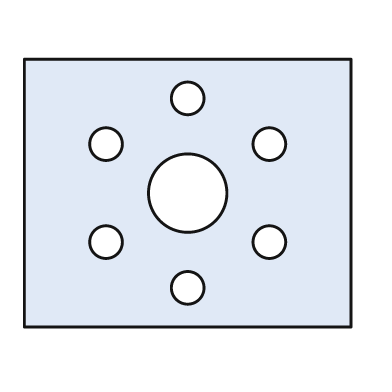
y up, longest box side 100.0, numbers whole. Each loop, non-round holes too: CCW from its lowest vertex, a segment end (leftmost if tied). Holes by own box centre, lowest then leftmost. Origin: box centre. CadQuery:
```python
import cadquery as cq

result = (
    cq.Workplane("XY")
    .moveTo(-50.0, -41.0)
    .lineTo(50.0, -41.0)
    .lineTo(50.0, 41.0)
    .lineTo(-50.0, 41.0)
    .close()
    .moveTo(0.0, -29.0)
    .circle(5.0)
    .moveTo(-25.0, -15.0)
    .circle(5.0)
    .moveTo(25.0, -15.0)
    .circle(5.0)
    .moveTo(0.0, 0.0)
    .circle(12.0)
    .moveTo(-25.0, 15.0)
    .circle(5.0)
    .moveTo(25.0, 15.0)
    .circle(5.0)
    .moveTo(0.0, 29.0)
    .circle(5.0)
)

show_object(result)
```